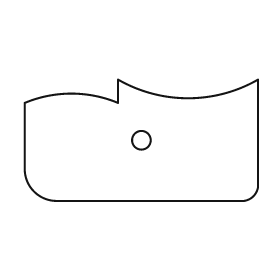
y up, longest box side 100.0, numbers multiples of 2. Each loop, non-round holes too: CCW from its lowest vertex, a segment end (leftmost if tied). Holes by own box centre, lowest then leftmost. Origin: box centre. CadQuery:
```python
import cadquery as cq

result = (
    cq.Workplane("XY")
    .moveTo(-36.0, -26.0)
    .lineTo(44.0, -26.0)
    .threePointArc((48.0, -24.0), (50.0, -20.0))
    .lineTo(50.0, 26.0)
    .threePointArc((20.0, 18.0), (-10.0, 26.0))
    .lineTo(-10.0, 16.0)
    .threePointArc((-30.0, 20.0), (-50.0, 16.0))
    .lineTo(-50.0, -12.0)
    .threePointArc((-46.0, -22.0), (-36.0, -26.0))
    .close()
    .moveTo(0.0, 0.0)
    .circle(4.0)
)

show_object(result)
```